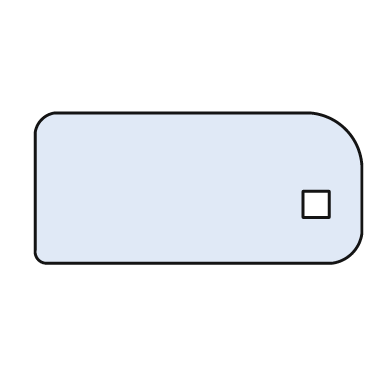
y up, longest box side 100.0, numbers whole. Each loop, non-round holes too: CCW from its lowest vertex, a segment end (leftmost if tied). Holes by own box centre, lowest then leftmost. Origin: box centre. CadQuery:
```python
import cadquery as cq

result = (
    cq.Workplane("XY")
    .moveTo(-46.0, -23.0)
    .lineTo(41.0, -23.0)
    .threePointArc((47.0, -20.0), (50.0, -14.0))
    .lineTo(50.0, 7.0)
    .threePointArc((45.0, 18.0), (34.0, 23.0))
    .lineTo(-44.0, 23.0)
    .threePointArc((-48.0, 21.0), (-50.0, 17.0))
    .lineTo(-50.0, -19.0)
    .threePointArc((-49.0, -22.0), (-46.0, -23.0))
    .close()
    .moveTo(32.0, -9.0)
    .lineTo(40.0, -9.0)
    .lineTo(40.0, -1.0)
    .lineTo(32.0, -1.0)
    .close()
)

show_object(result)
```